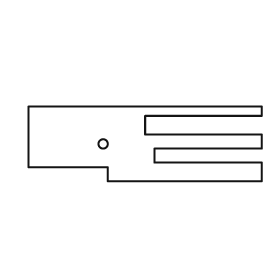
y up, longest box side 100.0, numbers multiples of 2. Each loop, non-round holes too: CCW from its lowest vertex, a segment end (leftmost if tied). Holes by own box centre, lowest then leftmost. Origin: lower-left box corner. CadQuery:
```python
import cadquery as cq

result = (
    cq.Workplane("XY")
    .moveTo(34.0, 0.0)
    .lineTo(100.0, 0.0)
    .lineTo(100.0, 8.0)
    .lineTo(54.0, 8.0)
    .lineTo(54.0, 14.0)
    .lineTo(100.0, 14.0)
    .lineTo(100.0, 20.0)
    .lineTo(50.0, 20.0)
    .lineTo(50.0, 28.0)
    .lineTo(100.0, 28.0)
    .lineTo(100.0, 32.0)
    .lineTo(0.0, 32.0)
    .lineTo(0.0, 6.0)
    .lineTo(34.0, 6.0)
    .close()
    .moveTo(32.0, 16.0)
    .circle(2.0)
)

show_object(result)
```